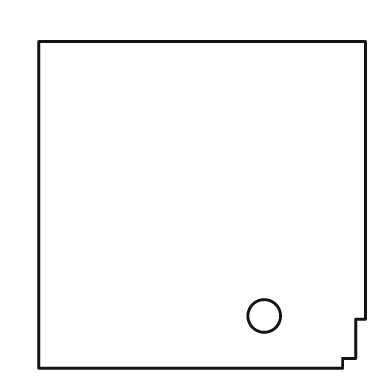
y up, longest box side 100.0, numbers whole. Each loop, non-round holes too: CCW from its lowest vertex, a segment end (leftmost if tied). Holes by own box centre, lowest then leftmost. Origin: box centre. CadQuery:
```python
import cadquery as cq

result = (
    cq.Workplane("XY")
    .moveTo(-50.0, -50.0)
    .lineTo(43.0, -50.0)
    .lineTo(43.0, -47.0)
    .lineTo(47.0, -47.0)
    .lineTo(47.0, -35.0)
    .lineTo(50.0, -35.0)
    .lineTo(50.0, 50.0)
    .lineTo(-50.0, 50.0)
    .close()
    .moveTo(19.0, -34.0)
    .circle(5.0)
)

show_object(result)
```